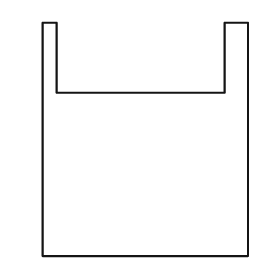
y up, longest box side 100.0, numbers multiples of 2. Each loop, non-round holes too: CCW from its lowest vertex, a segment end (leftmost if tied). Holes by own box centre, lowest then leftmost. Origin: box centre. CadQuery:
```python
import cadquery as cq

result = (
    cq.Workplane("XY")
    .moveTo(-44.0, -50.0)
    .lineTo(44.0, -50.0)
    .lineTo(44.0, 50.0)
    .lineTo(34.0, 50.0)
    .lineTo(34.0, 20.0)
    .lineTo(-38.0, 20.0)
    .lineTo(-38.0, 50.0)
    .lineTo(-44.0, 50.0)
    .close()
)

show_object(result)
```